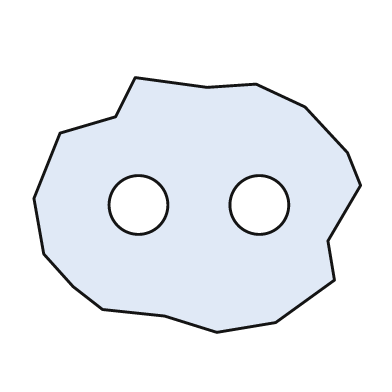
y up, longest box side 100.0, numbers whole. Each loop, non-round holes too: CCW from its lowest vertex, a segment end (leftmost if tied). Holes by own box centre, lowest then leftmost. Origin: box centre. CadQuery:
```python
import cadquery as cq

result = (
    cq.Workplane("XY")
    .moveTo(6.0, -39.0)
    .lineTo(24.0, -36.0)
    .lineTo(42.0, -23.0)
    .lineTo(40.0, -11.0)
    .lineTo(50.0, 6.0)
    .lineTo(46.0, 16.0)
    .lineTo(33.0, 30.0)
    .lineTo(18.0, 37.0)
    .lineTo(3.0, 36.0)
    .lineTo(-19.0, 39.0)
    .lineTo(-25.0, 27.0)
    .lineTo(-42.0, 22.0)
    .lineTo(-50.0, 2.0)
    .lineTo(-47.0, -15.0)
    .lineTo(-38.0, -25.0)
    .lineTo(-29.0, -32.0)
    .lineTo(-10.0, -34.0)
    .close()
    .moveTo(-18.0, 0.0)
    .circle(9.0)
    .moveTo(19.0, 0.0)
    .circle(9.0)
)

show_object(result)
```